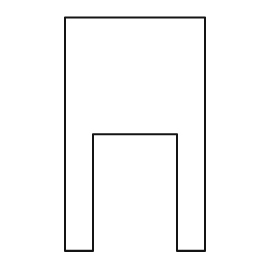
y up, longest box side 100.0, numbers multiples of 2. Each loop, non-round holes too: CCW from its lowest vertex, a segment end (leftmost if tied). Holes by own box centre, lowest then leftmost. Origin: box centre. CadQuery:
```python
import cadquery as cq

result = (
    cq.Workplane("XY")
    .moveTo(-30.0, -50.0)
    .lineTo(-18.0, -50.0)
    .lineTo(-18.0, 0.0)
    .lineTo(18.0, 0.0)
    .lineTo(18.0, -50.0)
    .lineTo(30.0, -50.0)
    .lineTo(30.0, 50.0)
    .lineTo(-30.0, 50.0)
    .close()
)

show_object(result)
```